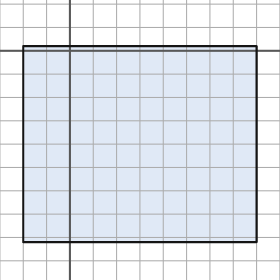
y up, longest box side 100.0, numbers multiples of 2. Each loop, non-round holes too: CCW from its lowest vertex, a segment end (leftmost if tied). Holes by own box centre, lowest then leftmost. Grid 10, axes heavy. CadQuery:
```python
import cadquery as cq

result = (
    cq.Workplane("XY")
    .moveTo(-20.0, -82.0)
    .lineTo(80.0, -82.0)
    .lineTo(80.0, 2.0)
    .lineTo(-20.0, 2.0)
    .close()
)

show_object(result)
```